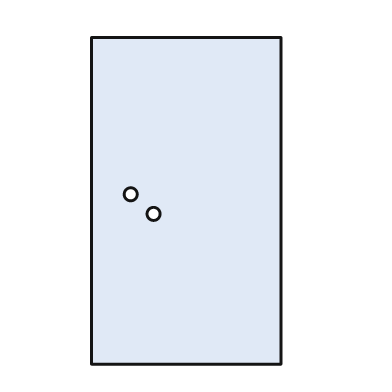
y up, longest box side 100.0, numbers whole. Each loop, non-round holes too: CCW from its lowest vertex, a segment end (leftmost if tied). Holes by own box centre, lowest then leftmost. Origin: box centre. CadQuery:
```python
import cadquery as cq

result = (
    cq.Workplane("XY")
    .moveTo(-29.0, -50.0)
    .lineTo(29.0, -50.0)
    .lineTo(29.0, 50.0)
    .lineTo(-29.0, 50.0)
    .close()
    .moveTo(-10.0, -4.0)
    .circle(2.0)
    .moveTo(-17.0, 2.0)
    .circle(2.0)
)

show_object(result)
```